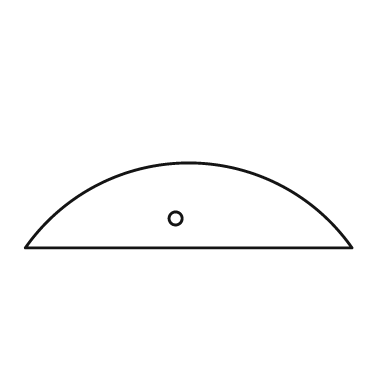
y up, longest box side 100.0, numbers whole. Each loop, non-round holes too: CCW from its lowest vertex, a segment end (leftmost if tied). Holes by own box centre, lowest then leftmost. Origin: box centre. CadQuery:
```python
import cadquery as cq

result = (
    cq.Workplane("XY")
    .moveTo(-50.0, -13.0)
    .lineTo(50.0, -13.0)
    .threePointArc((0.0, 13.0), (-50.0, -13.0))
    .close()
    .moveTo(-4.0, -4.0)
    .circle(2.0)
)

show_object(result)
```